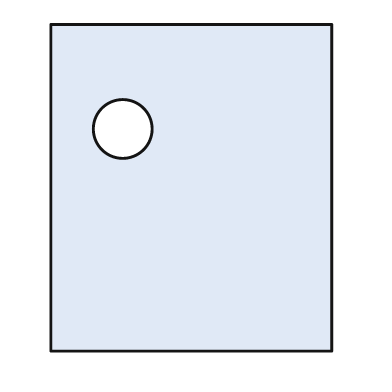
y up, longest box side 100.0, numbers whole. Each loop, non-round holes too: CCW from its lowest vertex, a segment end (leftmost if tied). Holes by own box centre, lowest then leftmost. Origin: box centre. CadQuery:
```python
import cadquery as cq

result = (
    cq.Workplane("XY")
    .moveTo(-43.0, -50.0)
    .lineTo(43.0, -50.0)
    .lineTo(43.0, 50.0)
    .lineTo(-43.0, 50.0)
    .close()
    .moveTo(-21.0, 18.0)
    .circle(9.0)
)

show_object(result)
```